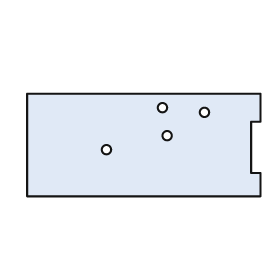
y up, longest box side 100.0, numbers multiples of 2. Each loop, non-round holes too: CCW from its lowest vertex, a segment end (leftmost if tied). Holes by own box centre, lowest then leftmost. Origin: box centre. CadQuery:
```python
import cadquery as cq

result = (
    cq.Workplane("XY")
    .moveTo(-50.0, -22.0)
    .lineTo(50.0, -22.0)
    .lineTo(50.0, -12.0)
    .lineTo(46.0, -12.0)
    .lineTo(46.0, 10.0)
    .lineTo(50.0, 10.0)
    .lineTo(50.0, 22.0)
    .lineTo(-50.0, 22.0)
    .close()
    .moveTo(-16.0, -2.0)
    .circle(2.0)
    .moveTo(10.0, 4.0)
    .circle(2.0)
    .moveTo(26.0, 14.0)
    .circle(2.0)
    .moveTo(8.0, 16.0)
    .circle(2.0)
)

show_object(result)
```